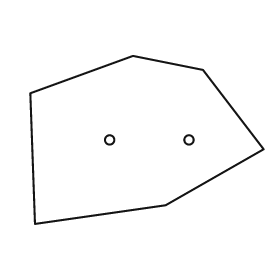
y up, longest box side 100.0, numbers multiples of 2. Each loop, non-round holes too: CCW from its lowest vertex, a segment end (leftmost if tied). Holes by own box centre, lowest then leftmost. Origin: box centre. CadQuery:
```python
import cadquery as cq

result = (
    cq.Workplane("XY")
    .moveTo(-48.0, -36.0)
    .lineTo(8.0, -28.0)
    .lineTo(50.0, -4.0)
    .lineTo(24.0, 30.0)
    .lineTo(-6.0, 36.0)
    .lineTo(-50.0, 20.0)
    .close()
    .moveTo(-16.0, 0.0)
    .circle(2.0)
    .moveTo(18.0, 0.0)
    .circle(2.0)
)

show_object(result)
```